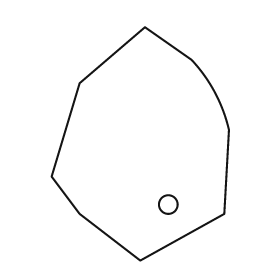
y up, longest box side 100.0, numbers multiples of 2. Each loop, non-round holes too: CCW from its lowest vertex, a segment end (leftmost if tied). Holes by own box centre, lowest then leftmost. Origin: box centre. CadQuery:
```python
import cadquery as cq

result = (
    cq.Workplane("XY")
    .moveTo(0.0, -50.0)
    .lineTo(36.0, -30.0)
    .lineTo(38.0, 6.0)
    .threePointArc((32.0, 22.0), (22.0, 36.0))
    .lineTo(2.0, 50.0)
    .lineTo(-26.0, 26.0)
    .lineTo(-38.0, -14.0)
    .lineTo(-26.0, -30.0)
    .close()
    .moveTo(12.0, -26.0)
    .circle(4.0)
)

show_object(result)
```